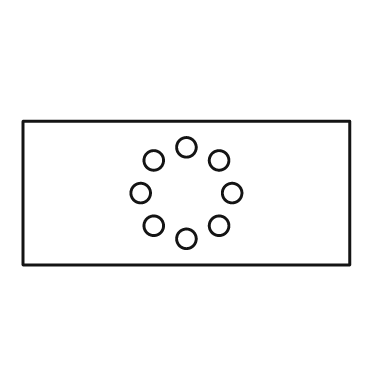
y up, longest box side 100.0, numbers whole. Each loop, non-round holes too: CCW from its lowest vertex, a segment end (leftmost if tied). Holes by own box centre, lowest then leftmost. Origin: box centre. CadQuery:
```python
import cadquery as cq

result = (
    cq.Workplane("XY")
    .moveTo(-50.0, -22.0)
    .lineTo(50.0, -22.0)
    .lineTo(50.0, 22.0)
    .lineTo(-50.0, 22.0)
    .close()
    .moveTo(0.0, -14.0)
    .circle(3.0)
    .moveTo(-10.0, -10.0)
    .circle(3.0)
    .moveTo(10.0, -10.0)
    .circle(3.0)
    .moveTo(-14.0, 0.0)
    .circle(3.0)
    .moveTo(14.0, 0.0)
    .circle(3.0)
    .moveTo(-10.0, 10.0)
    .circle(3.0)
    .moveTo(10.0, 10.0)
    .circle(3.0)
    .moveTo(0.0, 14.0)
    .circle(3.0)
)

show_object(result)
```